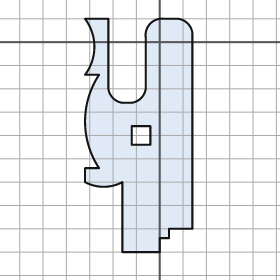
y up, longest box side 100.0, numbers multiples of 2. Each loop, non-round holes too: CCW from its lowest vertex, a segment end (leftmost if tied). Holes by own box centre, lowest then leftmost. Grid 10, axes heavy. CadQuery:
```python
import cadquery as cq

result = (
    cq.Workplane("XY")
    .moveTo(-16.0, -90.0)
    .lineTo(0.0, -90.0)
    .lineTo(0.0, -84.0)
    .lineTo(4.0, -84.0)
    .lineTo(4.0, -80.0)
    .lineTo(14.0, -80.0)
    .lineTo(14.0, 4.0)
    .threePointArc((12.0, 8.0), (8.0, 10.0))
    .lineTo(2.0, 10.0)
    .threePointArc((-4.0, 8.0), (-6.0, 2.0))
    .lineTo(-6.0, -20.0)
    .threePointArc((-8.0, -24.0), (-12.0, -26.0))
    .lineTo(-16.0, -26.0)
    .threePointArc((-20.0, -24.0), (-22.0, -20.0))
    .lineTo(-22.0, 10.0)
    .lineTo(-32.0, 10.0)
    .threePointArc((-28.0, -2.0), (-32.0, -14.0))
    .lineTo(-26.0, -14.0)
    .threePointArc((-32.0, -34.0), (-26.0, -54.0))
    .lineTo(-32.0, -54.0)
    .lineTo(-32.0, -60.0)
    .threePointArc((-24.0, -62.0), (-16.0, -60.0))
    .close()
    .moveTo(-12.0, -44.0)
    .lineTo(-4.0, -44.0)
    .lineTo(-4.0, -36.0)
    .lineTo(-12.0, -36.0)
    .close()
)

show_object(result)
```